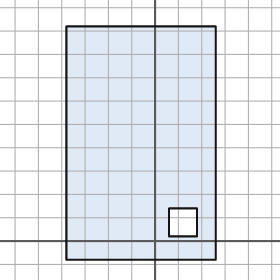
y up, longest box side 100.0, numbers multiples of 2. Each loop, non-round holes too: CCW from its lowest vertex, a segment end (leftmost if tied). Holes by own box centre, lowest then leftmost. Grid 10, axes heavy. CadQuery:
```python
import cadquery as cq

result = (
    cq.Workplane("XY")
    .moveTo(-38.0, -8.0)
    .lineTo(26.0, -8.0)
    .lineTo(26.0, 92.0)
    .lineTo(-38.0, 92.0)
    .close()
    .moveTo(6.0, 2.0)
    .lineTo(18.0, 2.0)
    .lineTo(18.0, 14.0)
    .lineTo(6.0, 14.0)
    .close()
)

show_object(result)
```